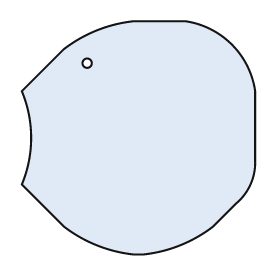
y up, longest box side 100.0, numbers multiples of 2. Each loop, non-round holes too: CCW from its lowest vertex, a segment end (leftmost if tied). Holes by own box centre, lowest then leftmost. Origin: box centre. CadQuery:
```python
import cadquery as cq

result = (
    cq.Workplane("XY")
    .moveTo(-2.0, -50.0)
    .lineTo(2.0, -50.0)
    .threePointArc((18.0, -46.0), (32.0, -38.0))
    .lineTo(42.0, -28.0)
    .threePointArc((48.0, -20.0), (50.0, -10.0))
    .lineTo(50.0, 20.0)
    .threePointArc((40.0, 40.0), (20.0, 50.0))
    .lineTo(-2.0, 50.0)
    .threePointArc((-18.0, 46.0), (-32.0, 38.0))
    .lineTo(-50.0, 20.0)
    .threePointArc((-46.0, 0.0), (-50.0, -20.0))
    .lineTo(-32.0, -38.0)
    .threePointArc((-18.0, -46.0), (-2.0, -50.0))
    .close()
    .moveTo(-22.0, 32.0)
    .circle(2.0)
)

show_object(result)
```